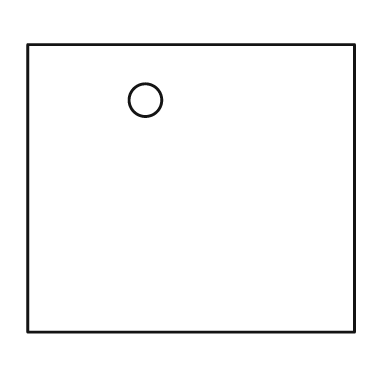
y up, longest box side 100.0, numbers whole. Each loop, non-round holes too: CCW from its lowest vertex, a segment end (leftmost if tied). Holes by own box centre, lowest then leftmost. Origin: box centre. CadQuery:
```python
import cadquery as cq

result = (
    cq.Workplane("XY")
    .moveTo(-50.0, -44.0)
    .lineTo(50.0, -44.0)
    .lineTo(50.0, 44.0)
    .lineTo(-50.0, 44.0)
    .close()
    .moveTo(-14.0, 27.0)
    .circle(5.0)
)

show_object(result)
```